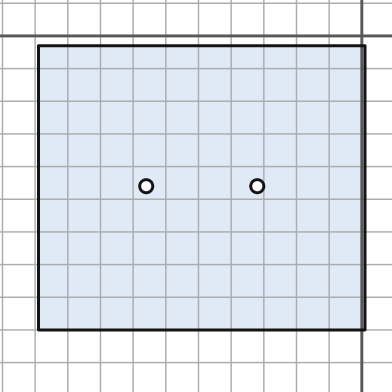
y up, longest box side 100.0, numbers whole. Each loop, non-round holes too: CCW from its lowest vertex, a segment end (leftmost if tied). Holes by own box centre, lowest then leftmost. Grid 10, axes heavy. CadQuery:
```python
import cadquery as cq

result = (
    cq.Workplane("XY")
    .moveTo(-99.0, -90.0)
    .lineTo(1.0, -90.0)
    .lineTo(1.0, -3.0)
    .lineTo(-99.0, -3.0)
    .close()
    .moveTo(-66.0, -46.0)
    .circle(2.0)
    .moveTo(-32.0, -46.0)
    .circle(2.0)
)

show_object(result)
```